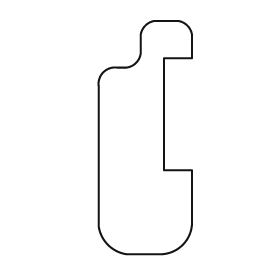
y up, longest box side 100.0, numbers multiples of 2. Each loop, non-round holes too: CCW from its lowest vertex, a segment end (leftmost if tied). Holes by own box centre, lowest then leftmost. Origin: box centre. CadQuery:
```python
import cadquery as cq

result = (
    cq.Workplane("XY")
    .moveTo(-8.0, -50.0)
    .lineTo(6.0, -50.0)
    .threePointArc((16.0, -46.0), (20.0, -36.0))
    .lineTo(20.0, -14.0)
    .lineTo(8.0, -14.0)
    .lineTo(8.0, 34.0)
    .lineTo(20.0, 34.0)
    .lineTo(20.0, 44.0)
    .threePointArc((18.0, 48.0), (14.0, 50.0))
    .lineTo(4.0, 50.0)
    .threePointArc((0.0, 48.0), (-2.0, 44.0))
    .lineTo(-2.0, 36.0)
    .threePointArc((-4.0, 32.0), (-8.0, 30.0))
    .lineTo(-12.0, 30.0)
    .threePointArc((-18.0, 28.0), (-20.0, 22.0))
    .lineTo(-20.0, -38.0)
    .threePointArc((-16.0, -46.0), (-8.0, -50.0))
    .close()
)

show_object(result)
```